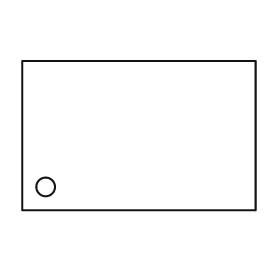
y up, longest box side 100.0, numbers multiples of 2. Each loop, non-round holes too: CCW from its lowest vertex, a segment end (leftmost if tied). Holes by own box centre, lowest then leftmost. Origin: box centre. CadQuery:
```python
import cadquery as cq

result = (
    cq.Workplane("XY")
    .moveTo(-50.0, -32.0)
    .lineTo(50.0, -32.0)
    .lineTo(50.0, 32.0)
    .lineTo(-50.0, 32.0)
    .close()
    .moveTo(-40.0, -22.0)
    .circle(4.0)
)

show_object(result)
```